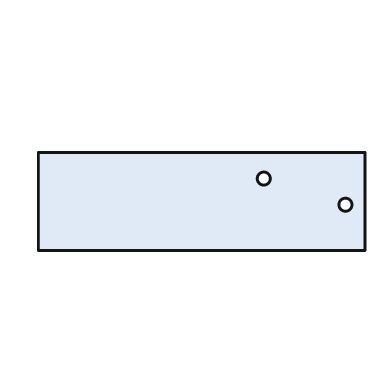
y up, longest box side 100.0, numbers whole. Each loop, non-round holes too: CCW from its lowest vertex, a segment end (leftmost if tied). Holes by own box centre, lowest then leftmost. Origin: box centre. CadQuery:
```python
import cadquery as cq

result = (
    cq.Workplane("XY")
    .moveTo(-50.0, -15.0)
    .lineTo(50.0, -15.0)
    .lineTo(50.0, 15.0)
    .lineTo(-50.0, 15.0)
    .close()
    .moveTo(44.0, -1.0)
    .circle(2.0)
    .moveTo(19.0, 7.0)
    .circle(2.0)
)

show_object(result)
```